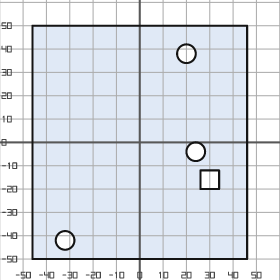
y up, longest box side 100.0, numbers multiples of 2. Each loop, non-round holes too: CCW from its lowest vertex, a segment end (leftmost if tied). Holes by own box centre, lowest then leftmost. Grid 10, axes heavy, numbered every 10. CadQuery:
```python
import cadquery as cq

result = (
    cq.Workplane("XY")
    .moveTo(-46.0, -50.0)
    .lineTo(46.0, -50.0)
    .lineTo(46.0, 50.0)
    .lineTo(-46.0, 50.0)
    .close()
    .moveTo(-32.0, -42.0)
    .circle(4.0)
    .moveTo(26.0, -20.0)
    .lineTo(34.0, -20.0)
    .lineTo(34.0, -12.0)
    .lineTo(26.0, -12.0)
    .close()
    .moveTo(24.0, -4.0)
    .circle(4.0)
    .moveTo(20.0, 38.0)
    .circle(4.0)
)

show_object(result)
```